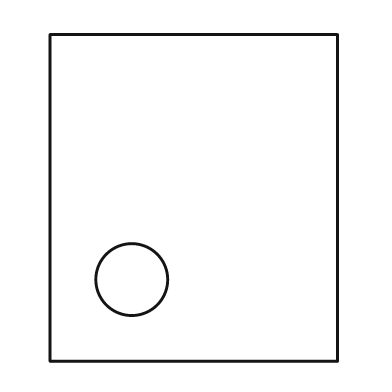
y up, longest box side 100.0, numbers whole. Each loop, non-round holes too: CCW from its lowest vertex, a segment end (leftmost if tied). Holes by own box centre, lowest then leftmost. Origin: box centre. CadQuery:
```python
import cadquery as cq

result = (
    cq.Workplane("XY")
    .moveTo(-44.0, -50.0)
    .lineTo(44.0, -50.0)
    .lineTo(44.0, 50.0)
    .lineTo(-44.0, 50.0)
    .close()
    .moveTo(-19.0, -25.0)
    .circle(11.0)
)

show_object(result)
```